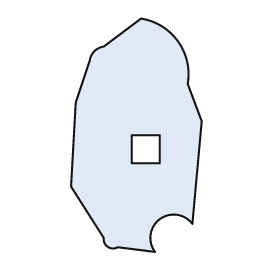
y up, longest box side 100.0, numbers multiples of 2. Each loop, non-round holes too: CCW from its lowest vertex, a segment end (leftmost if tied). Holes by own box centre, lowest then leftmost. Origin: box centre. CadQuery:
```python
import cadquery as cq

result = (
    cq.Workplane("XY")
    .moveTo(8.0, -50.0)
    .threePointArc((10.0, -36.0), (24.0, -38.0))
    .lineTo(28.0, 6.0)
    .lineTo(22.0, 22.0)
    .threePointArc((18.0, 40.0), (2.0, 50.0))
    .lineTo(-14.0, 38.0)
    .threePointArc((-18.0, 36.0), (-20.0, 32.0))
    .lineTo(-26.0, 14.0)
    .lineTo(-28.0, -22.0)
    .lineTo(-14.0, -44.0)
    .threePointArc((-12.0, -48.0), (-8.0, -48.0))
    .close()
    .moveTo(-2.0, -12.0)
    .lineTo(10.0, -12.0)
    .lineTo(10.0, 0.0)
    .lineTo(-2.0, 0.0)
    .close()
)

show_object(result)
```